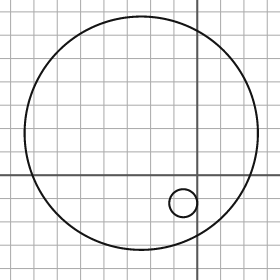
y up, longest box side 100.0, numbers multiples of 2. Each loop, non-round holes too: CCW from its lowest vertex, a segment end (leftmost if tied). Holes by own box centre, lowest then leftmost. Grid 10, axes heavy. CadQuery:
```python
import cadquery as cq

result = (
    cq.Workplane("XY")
    .moveTo(-24.0, 18.0)
    .circle(50.0)
    .moveTo(-6.0, -12.0)
    .circle(6.0)
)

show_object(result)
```